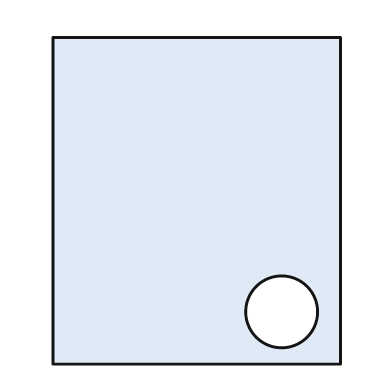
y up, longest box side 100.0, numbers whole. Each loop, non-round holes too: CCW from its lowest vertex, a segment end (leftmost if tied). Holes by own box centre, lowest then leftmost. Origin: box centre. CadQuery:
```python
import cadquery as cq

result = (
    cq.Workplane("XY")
    .moveTo(-44.0, -50.0)
    .lineTo(44.0, -50.0)
    .lineTo(44.0, 50.0)
    .lineTo(-44.0, 50.0)
    .close()
    .moveTo(26.0, -34.0)
    .circle(11.0)
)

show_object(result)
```